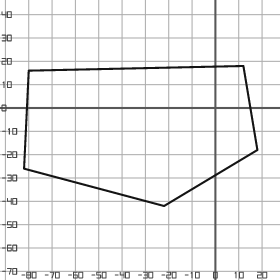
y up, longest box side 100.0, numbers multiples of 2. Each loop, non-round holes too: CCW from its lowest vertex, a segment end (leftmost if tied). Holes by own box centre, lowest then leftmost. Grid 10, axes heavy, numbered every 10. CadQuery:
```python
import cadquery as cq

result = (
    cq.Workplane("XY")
    .moveTo(-22.0, -42.0)
    .lineTo(18.0, -18.0)
    .lineTo(12.0, 18.0)
    .lineTo(-80.0, 16.0)
    .lineTo(-82.0, -26.0)
    .close()
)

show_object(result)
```